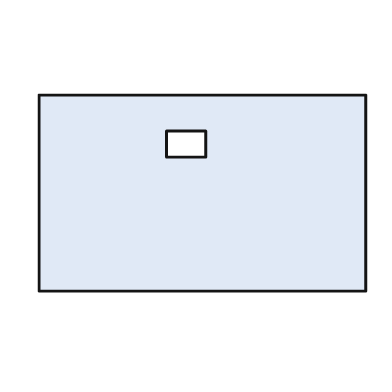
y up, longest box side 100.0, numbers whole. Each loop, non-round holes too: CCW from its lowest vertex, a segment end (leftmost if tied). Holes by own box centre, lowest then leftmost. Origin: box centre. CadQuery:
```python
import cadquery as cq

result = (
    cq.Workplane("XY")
    .moveTo(-50.0, -30.0)
    .lineTo(50.0, -30.0)
    .lineTo(50.0, 30.0)
    .lineTo(-50.0, 30.0)
    .close()
    .moveTo(-11.0, 11.0)
    .lineTo(1.0, 11.0)
    .lineTo(1.0, 19.0)
    .lineTo(-11.0, 19.0)
    .close()
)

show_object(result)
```